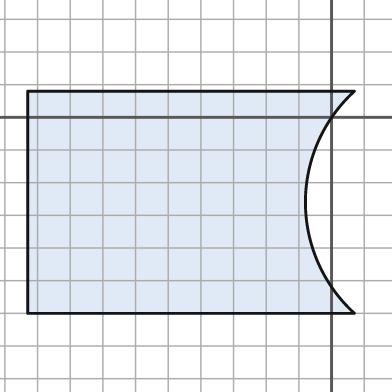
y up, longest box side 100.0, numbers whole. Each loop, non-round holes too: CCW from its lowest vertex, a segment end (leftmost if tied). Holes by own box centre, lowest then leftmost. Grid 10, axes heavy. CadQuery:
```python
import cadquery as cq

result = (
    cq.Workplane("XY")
    .moveTo(-93.0, -60.0)
    .lineTo(7.0, -60.0)
    .threePointArc((-8.0, -26.0), (7.0, 8.0))
    .lineTo(-93.0, 8.0)
    .close()
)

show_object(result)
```